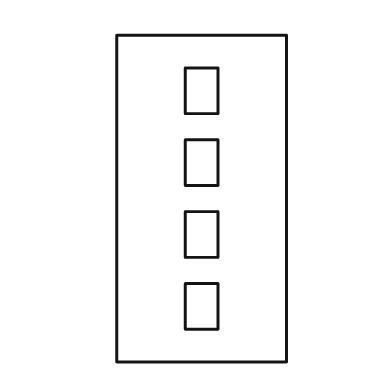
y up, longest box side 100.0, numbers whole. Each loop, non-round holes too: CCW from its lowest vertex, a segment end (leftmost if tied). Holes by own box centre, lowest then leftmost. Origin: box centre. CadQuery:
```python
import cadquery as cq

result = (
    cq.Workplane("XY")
    .moveTo(-26.0, -50.0)
    .lineTo(26.0, -50.0)
    .lineTo(26.0, 50.0)
    .lineTo(-26.0, 50.0)
    .close()
    .moveTo(-5.0, -40.0)
    .lineTo(5.0, -40.0)
    .lineTo(5.0, -26.0)
    .lineTo(-5.0, -26.0)
    .close()
    .moveTo(-5.0, -18.0)
    .lineTo(5.0, -18.0)
    .lineTo(5.0, -4.0)
    .lineTo(-5.0, -4.0)
    .close()
    .moveTo(-5.0, 4.0)
    .lineTo(5.0, 4.0)
    .lineTo(5.0, 18.0)
    .lineTo(-5.0, 18.0)
    .close()
    .moveTo(-5.0, 26.0)
    .lineTo(5.0, 26.0)
    .lineTo(5.0, 40.0)
    .lineTo(-5.0, 40.0)
    .close()
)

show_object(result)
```